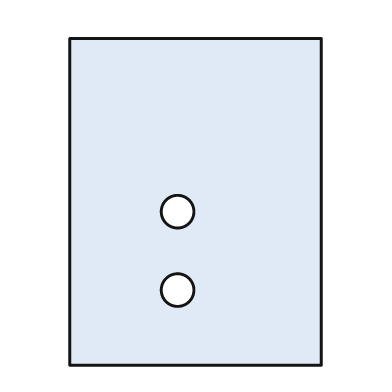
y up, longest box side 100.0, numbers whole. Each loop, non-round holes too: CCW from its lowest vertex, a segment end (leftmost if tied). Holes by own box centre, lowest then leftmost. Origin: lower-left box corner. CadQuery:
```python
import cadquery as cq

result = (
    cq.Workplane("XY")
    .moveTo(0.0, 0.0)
    .lineTo(77.0, 0.0)
    .lineTo(77.0, 100.0)
    .lineTo(0.0, 100.0)
    .close()
    .moveTo(33.0, 23.0)
    .circle(5.0)
    .moveTo(33.0, 47.0)
    .circle(5.0)
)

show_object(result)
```